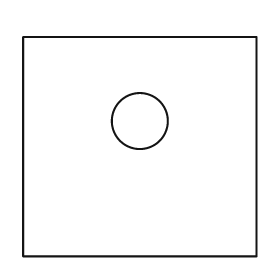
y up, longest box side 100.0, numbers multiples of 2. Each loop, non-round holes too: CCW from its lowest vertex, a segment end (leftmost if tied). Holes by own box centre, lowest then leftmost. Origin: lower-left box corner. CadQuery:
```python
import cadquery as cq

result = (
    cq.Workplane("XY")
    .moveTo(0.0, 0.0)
    .lineTo(100.0, 0.0)
    .lineTo(100.0, 94.0)
    .lineTo(0.0, 94.0)
    .close()
    .moveTo(50.0, 58.0)
    .circle(12.0)
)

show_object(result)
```